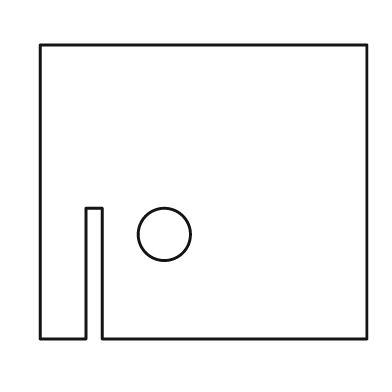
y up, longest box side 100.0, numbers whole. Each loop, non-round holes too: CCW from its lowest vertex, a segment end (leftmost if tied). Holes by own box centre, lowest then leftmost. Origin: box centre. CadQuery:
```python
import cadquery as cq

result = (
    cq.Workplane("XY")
    .moveTo(-50.0, -45.0)
    .lineTo(-36.0, -45.0)
    .lineTo(-36.0, -5.0)
    .lineTo(-31.0, -5.0)
    .lineTo(-31.0, -45.0)
    .lineTo(50.0, -45.0)
    .lineTo(50.0, 45.0)
    .lineTo(-50.0, 45.0)
    .close()
    .moveTo(-12.0, -13.0)
    .circle(8.0)
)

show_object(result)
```